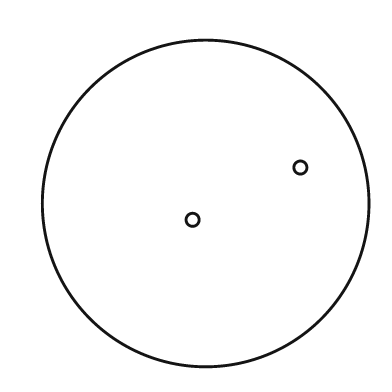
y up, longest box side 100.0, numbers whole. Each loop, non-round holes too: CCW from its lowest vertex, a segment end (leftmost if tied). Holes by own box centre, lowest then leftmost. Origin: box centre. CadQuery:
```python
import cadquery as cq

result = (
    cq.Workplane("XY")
    .moveTo(0.0, 0.0)
    .circle(50.0)
    .moveTo(-4.0, -5.0)
    .circle(2.0)
    .moveTo(29.0, 11.0)
    .circle(2.0)
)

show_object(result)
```